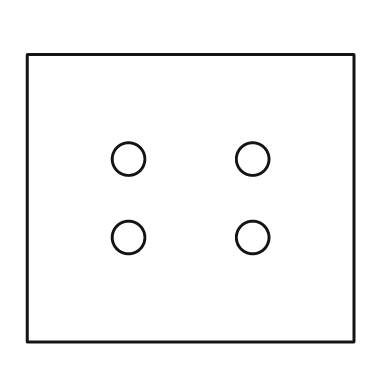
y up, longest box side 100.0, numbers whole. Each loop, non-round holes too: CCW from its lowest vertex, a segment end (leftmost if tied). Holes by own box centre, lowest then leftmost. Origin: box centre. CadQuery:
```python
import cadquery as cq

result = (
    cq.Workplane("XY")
    .moveTo(-50.0, -44.0)
    .lineTo(50.0, -44.0)
    .lineTo(50.0, 44.0)
    .lineTo(-50.0, 44.0)
    .close()
    .moveTo(-19.0, -12.0)
    .circle(5.0)
    .moveTo(19.0, -12.0)
    .circle(5.0)
    .moveTo(-19.0, 12.0)
    .circle(5.0)
    .moveTo(19.0, 12.0)
    .circle(5.0)
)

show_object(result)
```